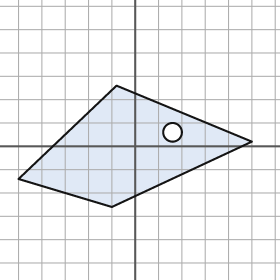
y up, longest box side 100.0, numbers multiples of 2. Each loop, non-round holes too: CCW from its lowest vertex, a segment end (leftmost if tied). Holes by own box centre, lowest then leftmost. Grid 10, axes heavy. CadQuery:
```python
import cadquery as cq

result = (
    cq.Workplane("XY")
    .moveTo(-10.0, -26.0)
    .lineTo(50.0, 2.0)
    .lineTo(-8.0, 26.0)
    .lineTo(-50.0, -14.0)
    .close()
    .moveTo(16.0, 6.0)
    .circle(4.0)
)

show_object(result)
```